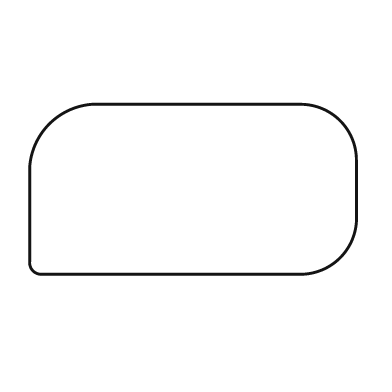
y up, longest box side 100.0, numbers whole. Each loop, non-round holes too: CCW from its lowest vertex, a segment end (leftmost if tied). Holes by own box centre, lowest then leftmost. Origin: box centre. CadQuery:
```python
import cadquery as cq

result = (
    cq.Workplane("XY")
    .moveTo(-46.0, -26.0)
    .lineTo(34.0, -26.0)
    .threePointArc((45.0, -21.0), (50.0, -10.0))
    .lineTo(50.0, 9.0)
    .threePointArc((45.0, 21.0), (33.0, 26.0))
    .lineTo(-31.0, 26.0)
    .threePointArc((-44.0, 20.0), (-50.0, 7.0))
    .lineTo(-50.0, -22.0)
    .threePointArc((-49.0, -25.0), (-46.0, -26.0))
    .close()
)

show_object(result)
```